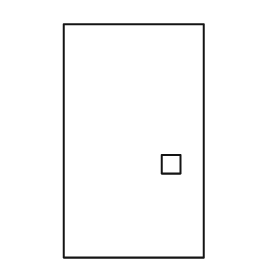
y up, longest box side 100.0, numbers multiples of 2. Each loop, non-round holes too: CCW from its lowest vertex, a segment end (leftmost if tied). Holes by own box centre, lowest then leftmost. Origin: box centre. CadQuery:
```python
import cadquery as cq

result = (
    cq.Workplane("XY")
    .moveTo(-30.0, -50.0)
    .lineTo(30.0, -50.0)
    .lineTo(30.0, 50.0)
    .lineTo(-30.0, 50.0)
    .close()
    .moveTo(12.0, -14.0)
    .lineTo(20.0, -14.0)
    .lineTo(20.0, -6.0)
    .lineTo(12.0, -6.0)
    .close()
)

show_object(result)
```